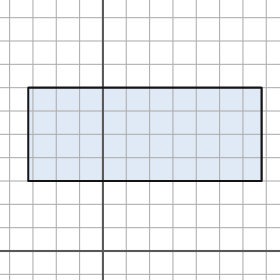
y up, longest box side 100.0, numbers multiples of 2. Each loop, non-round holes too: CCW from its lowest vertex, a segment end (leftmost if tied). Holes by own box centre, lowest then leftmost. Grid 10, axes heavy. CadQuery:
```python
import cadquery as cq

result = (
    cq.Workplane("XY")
    .moveTo(-32.0, 30.0)
    .lineTo(68.0, 30.0)
    .lineTo(68.0, 70.0)
    .lineTo(-32.0, 70.0)
    .close()
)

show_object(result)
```